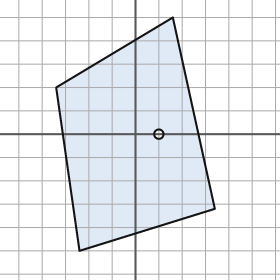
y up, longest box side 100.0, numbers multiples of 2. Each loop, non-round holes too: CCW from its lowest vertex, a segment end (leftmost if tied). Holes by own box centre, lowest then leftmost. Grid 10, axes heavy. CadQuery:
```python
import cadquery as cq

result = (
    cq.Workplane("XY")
    .moveTo(-24.0, -50.0)
    .lineTo(34.0, -32.0)
    .lineTo(16.0, 50.0)
    .lineTo(-34.0, 20.0)
    .close()
    .moveTo(10.0, 0.0)
    .circle(2.0)
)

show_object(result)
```